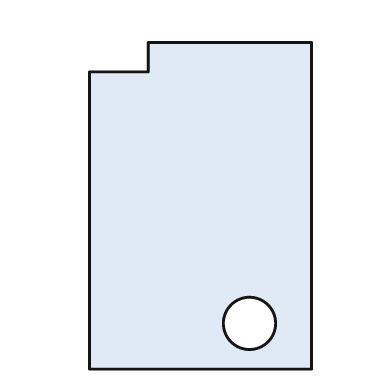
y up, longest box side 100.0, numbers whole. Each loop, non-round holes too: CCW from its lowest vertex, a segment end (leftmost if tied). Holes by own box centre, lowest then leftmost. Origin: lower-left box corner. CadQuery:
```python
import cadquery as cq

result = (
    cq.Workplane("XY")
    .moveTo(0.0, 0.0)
    .lineTo(68.0, 0.0)
    .lineTo(68.0, 100.0)
    .lineTo(18.0, 100.0)
    .lineTo(18.0, 91.0)
    .lineTo(0.0, 91.0)
    .close()
    .moveTo(49.0, 14.0)
    .circle(8.0)
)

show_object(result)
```